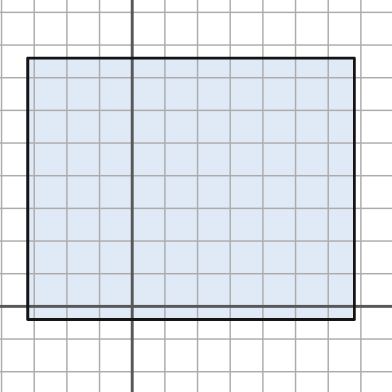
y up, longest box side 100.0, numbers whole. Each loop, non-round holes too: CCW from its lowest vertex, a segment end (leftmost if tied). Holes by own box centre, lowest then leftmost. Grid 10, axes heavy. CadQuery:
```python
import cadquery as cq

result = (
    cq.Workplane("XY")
    .moveTo(-32.0, -4.0)
    .lineTo(68.0, -4.0)
    .lineTo(68.0, 76.0)
    .lineTo(-32.0, 76.0)
    .close()
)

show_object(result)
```